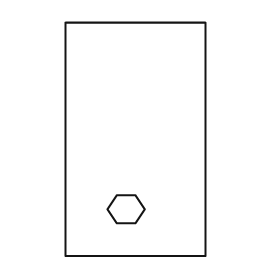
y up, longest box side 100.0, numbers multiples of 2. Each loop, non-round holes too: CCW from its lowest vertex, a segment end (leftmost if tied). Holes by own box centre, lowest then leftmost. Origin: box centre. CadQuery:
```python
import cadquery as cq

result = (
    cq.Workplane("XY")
    .moveTo(-30.0, -50.0)
    .lineTo(30.0, -50.0)
    .lineTo(30.0, 50.0)
    .lineTo(-30.0, 50.0)
    .close()
    .moveTo(-8.0, -36.0)
    .lineTo(0.0, -36.0)
    .lineTo(4.0, -30.0)
    .lineTo(0.0, -24.0)
    .lineTo(-8.0, -24.0)
    .lineTo(-12.0, -30.0)
    .close()
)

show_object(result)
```